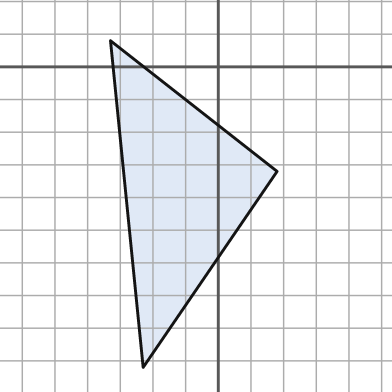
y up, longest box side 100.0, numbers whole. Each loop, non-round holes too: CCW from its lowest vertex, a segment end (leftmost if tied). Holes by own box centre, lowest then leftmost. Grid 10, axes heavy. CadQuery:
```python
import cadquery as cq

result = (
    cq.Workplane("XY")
    .moveTo(-23.0, -92.0)
    .lineTo(18.0, -32.0)
    .lineTo(-33.0, 8.0)
    .close()
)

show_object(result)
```